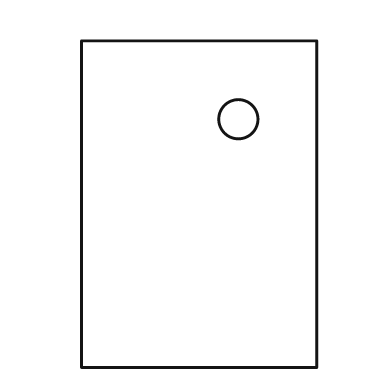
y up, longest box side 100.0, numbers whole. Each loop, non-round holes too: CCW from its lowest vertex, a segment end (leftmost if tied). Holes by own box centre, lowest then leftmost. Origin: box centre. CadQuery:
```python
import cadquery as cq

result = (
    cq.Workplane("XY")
    .moveTo(-36.0, -50.0)
    .lineTo(36.0, -50.0)
    .lineTo(36.0, 50.0)
    .lineTo(-36.0, 50.0)
    .close()
    .moveTo(12.0, 26.0)
    .circle(6.0)
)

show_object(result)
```